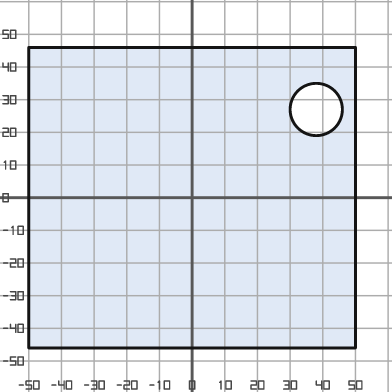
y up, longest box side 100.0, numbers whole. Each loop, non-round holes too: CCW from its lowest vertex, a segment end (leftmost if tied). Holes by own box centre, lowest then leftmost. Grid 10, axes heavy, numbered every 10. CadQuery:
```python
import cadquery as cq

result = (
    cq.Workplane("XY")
    .moveTo(-50.0, -46.0)
    .lineTo(50.0, -46.0)
    .lineTo(50.0, 46.0)
    .lineTo(-50.0, 46.0)
    .close()
    .moveTo(38.0, 27.0)
    .circle(8.0)
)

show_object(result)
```